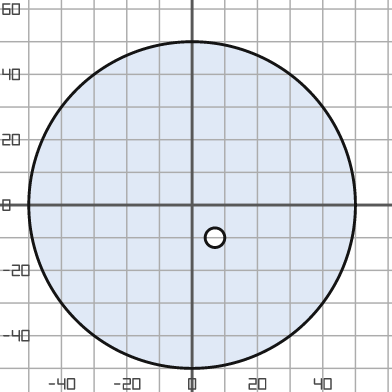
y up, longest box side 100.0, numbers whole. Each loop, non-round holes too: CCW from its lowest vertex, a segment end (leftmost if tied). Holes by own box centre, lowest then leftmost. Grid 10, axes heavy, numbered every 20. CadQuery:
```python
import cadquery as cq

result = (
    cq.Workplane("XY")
    .moveTo(0.0, 0.0)
    .circle(50.0)
    .moveTo(7.0, -10.0)
    .circle(3.0)
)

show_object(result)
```